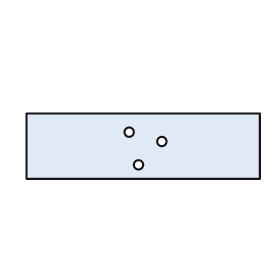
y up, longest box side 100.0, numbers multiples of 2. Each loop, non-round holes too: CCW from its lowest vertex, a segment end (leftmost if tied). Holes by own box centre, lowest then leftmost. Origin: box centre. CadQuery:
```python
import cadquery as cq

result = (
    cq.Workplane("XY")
    .moveTo(-50.0, -14.0)
    .lineTo(50.0, -14.0)
    .lineTo(50.0, 14.0)
    .lineTo(-50.0, 14.0)
    .close()
    .moveTo(-2.0, -8.0)
    .circle(2.0)
    .moveTo(8.0, 2.0)
    .circle(2.0)
    .moveTo(-6.0, 6.0)
    .circle(2.0)
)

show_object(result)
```